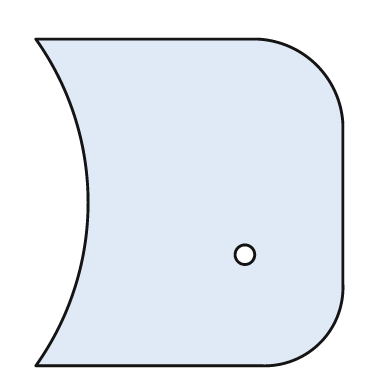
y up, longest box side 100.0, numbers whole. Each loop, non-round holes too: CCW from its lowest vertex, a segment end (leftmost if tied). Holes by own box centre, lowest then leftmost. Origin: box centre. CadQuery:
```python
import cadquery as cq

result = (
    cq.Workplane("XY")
    .moveTo(-47.0, -50.0)
    .lineTo(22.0, -50.0)
    .threePointArc((40.0, -43.0), (47.0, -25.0))
    .lineTo(47.0, 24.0)
    .threePointArc((39.0, 42.0), (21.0, 50.0))
    .lineTo(-47.0, 50.0)
    .threePointArc((-31.0, 0.0), (-47.0, -50.0))
    .close()
    .moveTo(17.0, -16.0)
    .circle(3.0)
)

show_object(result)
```